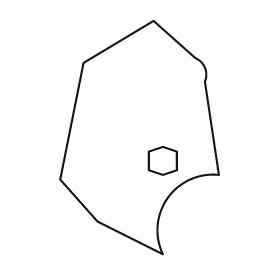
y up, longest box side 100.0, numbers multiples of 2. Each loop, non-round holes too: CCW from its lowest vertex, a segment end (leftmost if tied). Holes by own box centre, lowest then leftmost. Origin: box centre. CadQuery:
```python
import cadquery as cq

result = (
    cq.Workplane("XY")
    .moveTo(10.0, -50.0)
    .threePointArc((12.0, -26.0), (34.0, -16.0))
    .lineTo(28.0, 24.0)
    .threePointArc((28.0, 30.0), (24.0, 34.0))
    .lineTo(6.0, 50.0)
    .lineTo(-24.0, 32.0)
    .lineTo(-34.0, -18.0)
    .lineTo(-18.0, -36.0)
    .close()
    .moveTo(10.0, -16.0)
    .lineTo(16.0, -14.0)
    .lineTo(16.0, -6.0)
    .lineTo(10.0, -4.0)
    .lineTo(4.0, -6.0)
    .lineTo(4.0, -14.0)
    .close()
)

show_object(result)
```